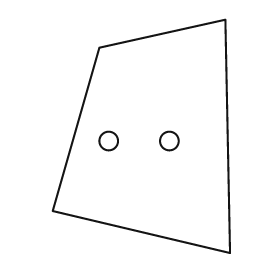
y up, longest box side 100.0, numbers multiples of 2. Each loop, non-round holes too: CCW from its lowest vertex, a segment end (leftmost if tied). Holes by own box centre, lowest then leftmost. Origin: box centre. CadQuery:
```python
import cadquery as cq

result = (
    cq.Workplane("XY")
    .moveTo(38.0, -50.0)
    .lineTo(36.0, 50.0)
    .lineTo(-18.0, 38.0)
    .lineTo(-38.0, -32.0)
    .close()
    .moveTo(-14.0, -2.0)
    .circle(4.0)
    .moveTo(12.0, -2.0)
    .circle(4.0)
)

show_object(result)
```